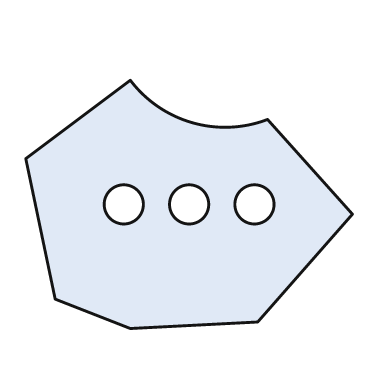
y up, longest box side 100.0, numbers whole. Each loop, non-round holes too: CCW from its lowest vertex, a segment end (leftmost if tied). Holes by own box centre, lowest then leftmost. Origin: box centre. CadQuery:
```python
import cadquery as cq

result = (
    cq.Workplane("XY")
    .moveTo(-18.0, -38.0)
    .lineTo(21.0, -36.0)
    .lineTo(50.0, -3.0)
    .lineTo(24.0, 26.0)
    .threePointArc((1.0, 25.0), (-18.0, 38.0))
    .lineTo(-50.0, 14.0)
    .lineTo(-41.0, -29.0)
    .close()
    .moveTo(-20.0, 0.0)
    .circle(6.0)
    .moveTo(0.0, 0.0)
    .circle(6.0)
    .moveTo(20.0, 0.0)
    .circle(6.0)
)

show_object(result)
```